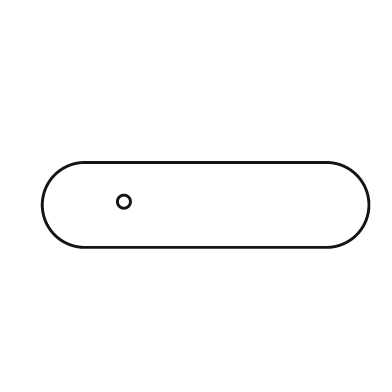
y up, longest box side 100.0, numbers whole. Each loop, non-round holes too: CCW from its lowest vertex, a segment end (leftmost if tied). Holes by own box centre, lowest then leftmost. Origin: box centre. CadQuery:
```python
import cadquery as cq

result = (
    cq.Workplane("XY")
    .moveTo(-37.0, -13.0)
    .lineTo(37.0, -13.0)
    .threePointArc((50.0, 0.0), (37.0, 13.0))
    .lineTo(-37.0, 13.0)
    .threePointArc((-50.0, 0.0), (-37.0, -13.0))
    .close()
    .moveTo(-25.0, 1.0)
    .circle(2.0)
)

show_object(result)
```